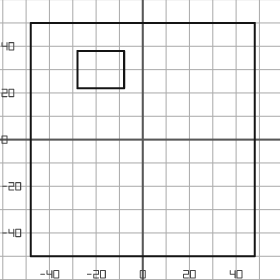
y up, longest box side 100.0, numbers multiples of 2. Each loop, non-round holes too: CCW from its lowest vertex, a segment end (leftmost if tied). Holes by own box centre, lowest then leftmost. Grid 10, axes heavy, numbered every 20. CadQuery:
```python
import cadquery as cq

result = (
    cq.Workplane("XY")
    .moveTo(-48.0, -50.0)
    .lineTo(48.0, -50.0)
    .lineTo(48.0, 50.0)
    .lineTo(-48.0, 50.0)
    .close()
    .moveTo(-28.0, 22.0)
    .lineTo(-8.0, 22.0)
    .lineTo(-8.0, 38.0)
    .lineTo(-28.0, 38.0)
    .close()
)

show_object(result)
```